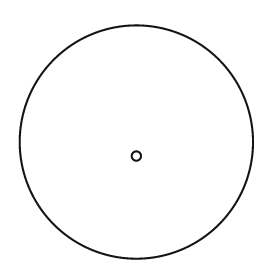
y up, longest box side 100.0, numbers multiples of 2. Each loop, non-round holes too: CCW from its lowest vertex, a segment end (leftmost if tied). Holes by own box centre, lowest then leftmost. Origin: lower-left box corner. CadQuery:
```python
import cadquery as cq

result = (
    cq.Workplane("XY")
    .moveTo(50.0, 50.0)
    .circle(50.0)
    .moveTo(50.0, 44.0)
    .circle(2.0)
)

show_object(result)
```